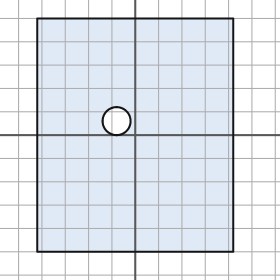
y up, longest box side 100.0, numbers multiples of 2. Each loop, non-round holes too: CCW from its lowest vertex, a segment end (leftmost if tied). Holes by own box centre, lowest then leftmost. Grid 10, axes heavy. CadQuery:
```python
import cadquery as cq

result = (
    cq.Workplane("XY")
    .moveTo(-42.0, -50.0)
    .lineTo(42.0, -50.0)
    .lineTo(42.0, 50.0)
    .lineTo(-42.0, 50.0)
    .close()
    .moveTo(-8.0, 6.0)
    .circle(6.0)
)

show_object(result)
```